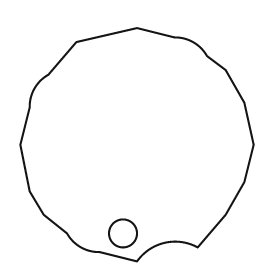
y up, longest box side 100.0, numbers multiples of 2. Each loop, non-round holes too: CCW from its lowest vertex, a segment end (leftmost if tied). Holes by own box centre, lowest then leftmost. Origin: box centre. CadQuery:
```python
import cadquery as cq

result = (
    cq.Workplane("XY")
    .moveTo(0.0, -50.0)
    .threePointArc((12.0, -42.0), (26.0, -44.0))
    .lineTo(38.0, -30.0)
    .lineTo(46.0, -16.0)
    .lineTo(50.0, 0.0)
    .lineTo(46.0, 18.0)
    .lineTo(38.0, 32.0)
    .lineTo(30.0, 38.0)
    .threePointArc((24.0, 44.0), (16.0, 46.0))
    .lineTo(0.0, 50.0)
    .lineTo(-26.0, 44.0)
    .lineTo(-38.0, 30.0)
    .threePointArc((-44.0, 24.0), (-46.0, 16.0))
    .lineTo(-50.0, 0.0)
    .lineTo(-46.0, -20.0)
    .lineTo(-40.0, -30.0)
    .lineTo(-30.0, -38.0)
    .threePointArc((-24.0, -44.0), (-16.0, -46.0))
    .close()
    .moveTo(-6.0, -38.0)
    .circle(6.0)
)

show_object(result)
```